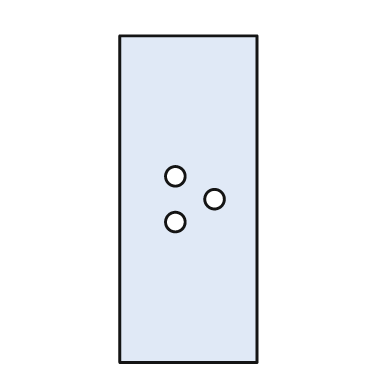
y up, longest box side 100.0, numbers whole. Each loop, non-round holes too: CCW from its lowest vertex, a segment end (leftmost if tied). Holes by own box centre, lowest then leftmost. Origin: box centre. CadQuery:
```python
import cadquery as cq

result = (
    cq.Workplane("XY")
    .moveTo(-21.0, -50.0)
    .lineTo(21.0, -50.0)
    .lineTo(21.0, 50.0)
    .lineTo(-21.0, 50.0)
    .close()
    .moveTo(-4.0, -7.0)
    .circle(3.0)
    .moveTo(8.0, 0.0)
    .circle(3.0)
    .moveTo(-4.0, 7.0)
    .circle(3.0)
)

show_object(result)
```